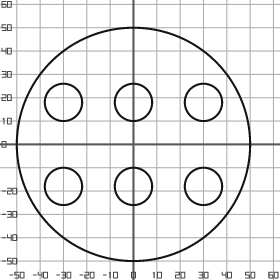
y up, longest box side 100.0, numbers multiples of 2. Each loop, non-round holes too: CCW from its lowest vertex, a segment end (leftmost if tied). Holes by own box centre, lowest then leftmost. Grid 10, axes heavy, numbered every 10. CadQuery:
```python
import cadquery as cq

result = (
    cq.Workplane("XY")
    .moveTo(0.0, 0.0)
    .circle(50.0)
    .moveTo(-30.0, -18.0)
    .circle(8.0)
    .moveTo(0.0, -18.0)
    .circle(8.0)
    .moveTo(30.0, -18.0)
    .circle(8.0)
    .moveTo(-30.0, 18.0)
    .circle(8.0)
    .moveTo(0.0, 18.0)
    .circle(8.0)
    .moveTo(30.0, 18.0)
    .circle(8.0)
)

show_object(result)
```